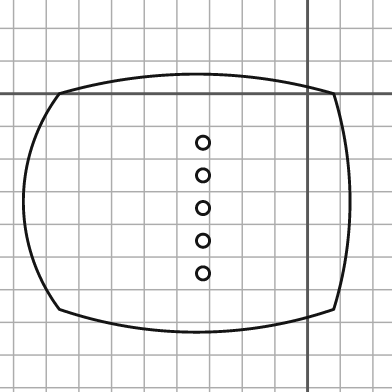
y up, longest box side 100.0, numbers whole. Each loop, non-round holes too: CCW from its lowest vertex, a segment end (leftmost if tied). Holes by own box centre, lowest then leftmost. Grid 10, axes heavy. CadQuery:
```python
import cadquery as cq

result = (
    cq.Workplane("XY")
    .moveTo(-76.0, -66.0)
    .threePointArc((-34.0, -73.0), (8.0, -66.0))
    .threePointArc((13.0, -33.0), (8.0, 0.0))
    .threePointArc((-34.0, 6.0), (-76.0, 0.0))
    .threePointArc((-87.0, -33.0), (-76.0, -66.0))
    .close()
    .moveTo(-32.0, -55.0)
    .circle(2.0)
    .moveTo(-32.0, -45.0)
    .circle(2.0)
    .moveTo(-32.0, -35.0)
    .circle(2.0)
    .moveTo(-32.0, -25.0)
    .circle(2.0)
    .moveTo(-32.0, -15.0)
    .circle(2.0)
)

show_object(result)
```